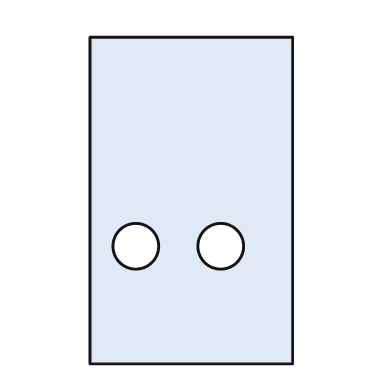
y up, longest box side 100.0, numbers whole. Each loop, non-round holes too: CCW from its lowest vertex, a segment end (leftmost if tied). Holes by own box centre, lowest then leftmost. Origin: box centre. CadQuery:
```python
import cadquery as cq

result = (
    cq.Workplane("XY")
    .moveTo(-31.0, -50.0)
    .lineTo(31.0, -50.0)
    .lineTo(31.0, 50.0)
    .lineTo(-31.0, 50.0)
    .close()
    .moveTo(-17.0, -14.0)
    .circle(7.0)
    .moveTo(9.0, -14.0)
    .circle(7.0)
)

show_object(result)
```